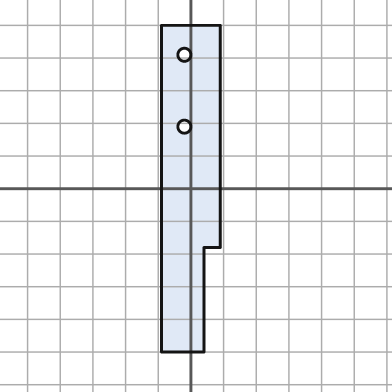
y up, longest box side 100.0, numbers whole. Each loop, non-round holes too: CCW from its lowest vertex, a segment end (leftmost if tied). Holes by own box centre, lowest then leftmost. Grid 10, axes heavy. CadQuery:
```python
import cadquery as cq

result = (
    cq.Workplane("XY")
    .moveTo(-9.0, -50.0)
    .lineTo(4.0, -50.0)
    .lineTo(4.0, -18.0)
    .lineTo(9.0, -18.0)
    .lineTo(9.0, 50.0)
    .lineTo(-9.0, 50.0)
    .close()
    .moveTo(-2.0, 19.0)
    .circle(2.0)
    .moveTo(-2.0, 41.0)
    .circle(2.0)
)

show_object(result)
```